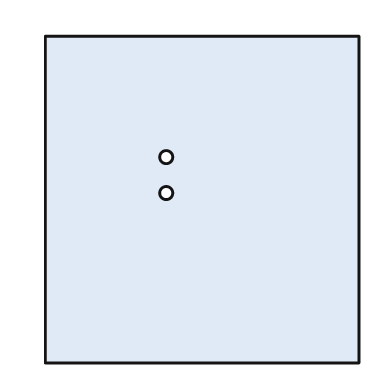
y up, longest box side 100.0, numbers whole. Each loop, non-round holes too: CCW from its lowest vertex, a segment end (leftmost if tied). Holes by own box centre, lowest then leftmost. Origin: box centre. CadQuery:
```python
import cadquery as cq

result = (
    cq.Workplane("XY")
    .moveTo(-48.0, -50.0)
    .lineTo(48.0, -50.0)
    .lineTo(48.0, 50.0)
    .lineTo(-48.0, 50.0)
    .close()
    .moveTo(-11.0, 2.0)
    .circle(2.0)
    .moveTo(-11.0, 13.0)
    .circle(2.0)
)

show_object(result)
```